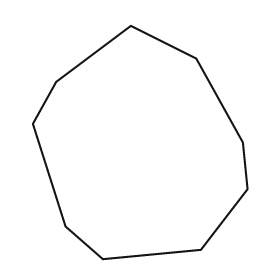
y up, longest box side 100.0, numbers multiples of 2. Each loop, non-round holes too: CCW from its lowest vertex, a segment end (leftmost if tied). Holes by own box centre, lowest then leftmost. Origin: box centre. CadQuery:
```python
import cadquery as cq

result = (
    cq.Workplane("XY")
    .moveTo(-16.0, -50.0)
    .lineTo(26.0, -46.0)
    .lineTo(46.0, -20.0)
    .lineTo(44.0, 0.0)
    .lineTo(24.0, 36.0)
    .lineTo(-4.0, 50.0)
    .lineTo(-36.0, 26.0)
    .lineTo(-46.0, 8.0)
    .lineTo(-32.0, -36.0)
    .close()
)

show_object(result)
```